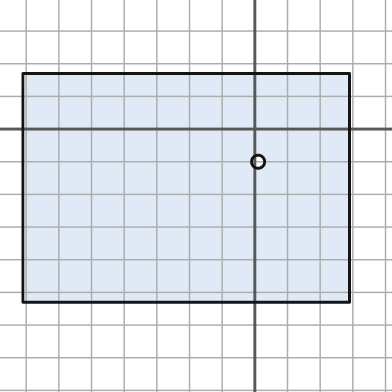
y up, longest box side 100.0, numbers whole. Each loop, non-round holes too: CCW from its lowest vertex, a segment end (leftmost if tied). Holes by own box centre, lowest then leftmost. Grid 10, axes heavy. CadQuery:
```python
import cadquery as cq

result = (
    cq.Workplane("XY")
    .moveTo(-71.0, -53.0)
    .lineTo(29.0, -53.0)
    .lineTo(29.0, 17.0)
    .lineTo(-71.0, 17.0)
    .close()
    .moveTo(1.0, -10.0)
    .circle(2.0)
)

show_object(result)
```